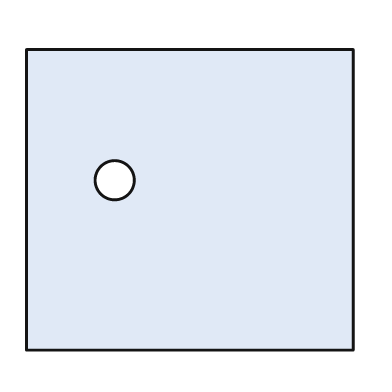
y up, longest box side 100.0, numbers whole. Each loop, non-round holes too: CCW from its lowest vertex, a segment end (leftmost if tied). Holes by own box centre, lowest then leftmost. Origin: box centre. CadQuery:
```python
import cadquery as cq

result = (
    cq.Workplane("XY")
    .moveTo(-50.0, -46.0)
    .lineTo(50.0, -46.0)
    .lineTo(50.0, 46.0)
    .lineTo(-50.0, 46.0)
    .close()
    .moveTo(-23.0, 6.0)
    .circle(6.0)
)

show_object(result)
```